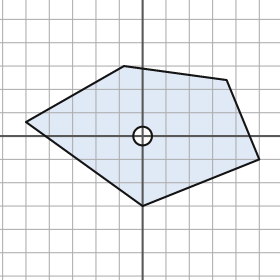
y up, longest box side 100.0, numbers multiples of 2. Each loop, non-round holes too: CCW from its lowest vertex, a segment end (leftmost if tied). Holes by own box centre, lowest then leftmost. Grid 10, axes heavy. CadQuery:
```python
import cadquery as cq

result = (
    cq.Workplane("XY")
    .moveTo(0.0, -30.0)
    .lineTo(50.0, -10.0)
    .lineTo(36.0, 24.0)
    .lineTo(-8.0, 30.0)
    .lineTo(-50.0, 6.0)
    .close()
    .moveTo(0.0, 0.0)
    .circle(4.0)
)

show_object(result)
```